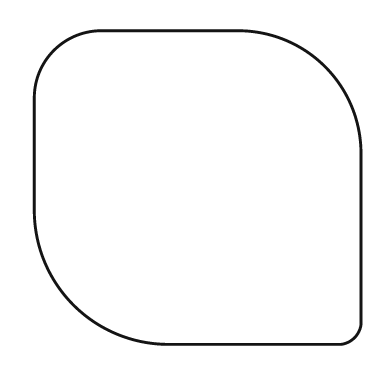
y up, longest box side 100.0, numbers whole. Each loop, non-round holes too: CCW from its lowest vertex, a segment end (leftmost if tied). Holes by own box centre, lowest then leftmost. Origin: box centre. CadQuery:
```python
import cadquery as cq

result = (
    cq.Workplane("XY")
    .moveTo(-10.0, -48.0)
    .lineTo(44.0, -48.0)
    .threePointArc((48.0, -46.0), (50.0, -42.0))
    .lineTo(50.0, 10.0)
    .threePointArc((39.0, 37.0), (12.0, 48.0))
    .lineTo(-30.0, 48.0)
    .threePointArc((-44.0, 42.0), (-50.0, 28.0))
    .lineTo(-50.0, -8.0)
    .threePointArc((-38.0, -36.0), (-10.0, -48.0))
    .close()
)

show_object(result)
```